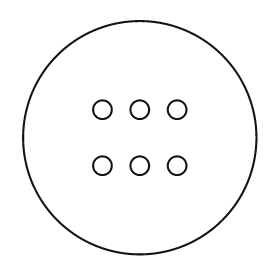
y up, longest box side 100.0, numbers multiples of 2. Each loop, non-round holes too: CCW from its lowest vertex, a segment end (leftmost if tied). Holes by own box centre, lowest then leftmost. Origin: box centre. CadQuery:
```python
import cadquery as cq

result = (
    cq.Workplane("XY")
    .moveTo(0.0, 0.0)
    .circle(50.0)
    .moveTo(-16.0, -12.0)
    .circle(4.0)
    .moveTo(0.0, -12.0)
    .circle(4.0)
    .moveTo(16.0, -12.0)
    .circle(4.0)
    .moveTo(-16.0, 12.0)
    .circle(4.0)
    .moveTo(0.0, 12.0)
    .circle(4.0)
    .moveTo(16.0, 12.0)
    .circle(4.0)
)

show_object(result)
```